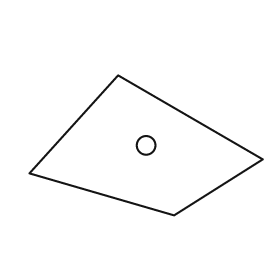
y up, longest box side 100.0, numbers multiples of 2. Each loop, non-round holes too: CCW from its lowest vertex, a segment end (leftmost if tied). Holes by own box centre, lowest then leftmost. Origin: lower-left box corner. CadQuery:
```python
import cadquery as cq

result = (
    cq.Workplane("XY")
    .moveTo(62.0, 0.0)
    .lineTo(100.0, 24.0)
    .lineTo(38.0, 60.0)
    .lineTo(0.0, 18.0)
    .close()
    .moveTo(50.0, 30.0)
    .circle(4.0)
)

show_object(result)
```